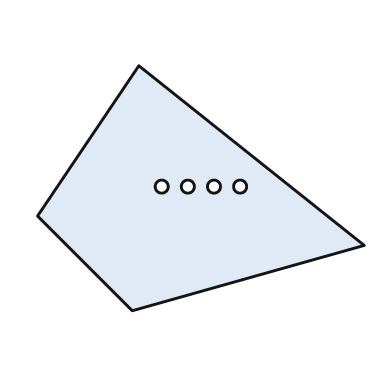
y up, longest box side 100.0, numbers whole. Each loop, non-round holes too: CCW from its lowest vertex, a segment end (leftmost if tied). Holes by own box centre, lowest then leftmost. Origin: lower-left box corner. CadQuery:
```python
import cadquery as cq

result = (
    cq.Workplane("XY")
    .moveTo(29.0, 0.0)
    .lineTo(100.0, 20.0)
    .lineTo(31.0, 75.0)
    .lineTo(0.0, 29.0)
    .close()
    .moveTo(38.0, 38.0)
    .circle(2.0)
    .moveTo(46.0, 38.0)
    .circle(2.0)
    .moveTo(54.0, 38.0)
    .circle(2.0)
    .moveTo(62.0, 38.0)
    .circle(2.0)
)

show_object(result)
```